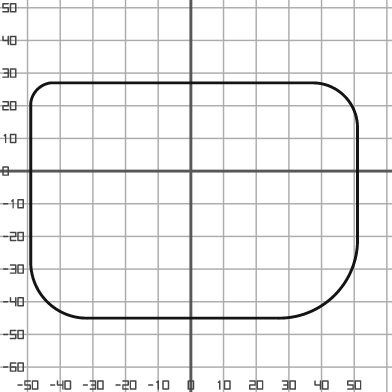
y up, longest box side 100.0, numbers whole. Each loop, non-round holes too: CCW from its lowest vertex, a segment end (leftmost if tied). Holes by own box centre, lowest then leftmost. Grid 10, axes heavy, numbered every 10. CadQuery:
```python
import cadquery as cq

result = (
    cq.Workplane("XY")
    .moveTo(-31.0, -45.0)
    .lineTo(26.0, -45.0)
    .threePointArc((44.0, -38.0), (51.0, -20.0))
    .lineTo(51.0, 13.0)
    .threePointArc((47.0, 23.0), (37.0, 27.0))
    .lineTo(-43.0, 27.0)
    .threePointArc((-47.0, 25.0), (-49.0, 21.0))
    .lineTo(-49.0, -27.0)
    .threePointArc((-44.0, -40.0), (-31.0, -45.0))
    .close()
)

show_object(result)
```